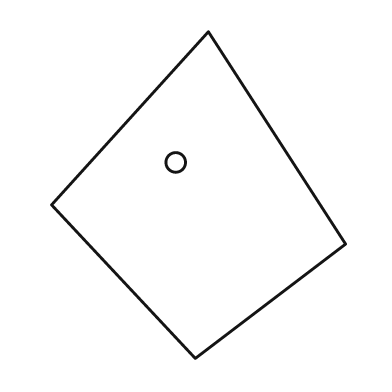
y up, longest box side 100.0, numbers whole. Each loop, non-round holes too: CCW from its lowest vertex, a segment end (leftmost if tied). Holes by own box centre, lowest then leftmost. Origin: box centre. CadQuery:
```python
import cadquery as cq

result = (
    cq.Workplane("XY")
    .moveTo(-1.0, -50.0)
    .lineTo(45.0, -15.0)
    .lineTo(3.0, 50.0)
    .lineTo(-45.0, -3.0)
    .close()
    .moveTo(-7.0, 10.0)
    .circle(3.0)
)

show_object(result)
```